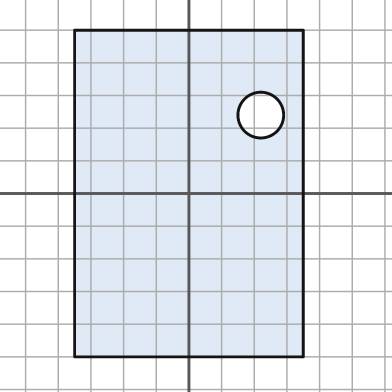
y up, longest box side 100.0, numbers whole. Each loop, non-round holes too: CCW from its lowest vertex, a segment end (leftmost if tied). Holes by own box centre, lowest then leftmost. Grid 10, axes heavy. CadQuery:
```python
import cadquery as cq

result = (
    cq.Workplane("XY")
    .moveTo(-35.0, -50.0)
    .lineTo(35.0, -50.0)
    .lineTo(35.0, 50.0)
    .lineTo(-35.0, 50.0)
    .close()
    .moveTo(22.0, 24.0)
    .circle(7.0)
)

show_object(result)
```